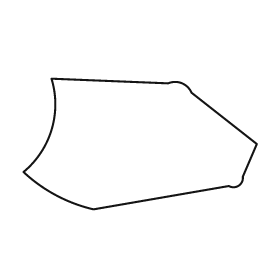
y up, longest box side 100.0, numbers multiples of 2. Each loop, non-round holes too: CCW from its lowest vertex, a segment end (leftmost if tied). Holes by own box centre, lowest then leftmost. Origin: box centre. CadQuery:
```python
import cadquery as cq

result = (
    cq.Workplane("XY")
    .moveTo(-20.0, -28.0)
    .lineTo(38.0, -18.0)
    .threePointArc((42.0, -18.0), (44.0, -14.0))
    .lineTo(50.0, 0.0)
    .lineTo(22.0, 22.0)
    .threePointArc((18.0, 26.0), (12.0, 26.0))
    .lineTo(-38.0, 28.0)
    .threePointArc((-38.0, 6.0), (-50.0, -12.0))
    .threePointArc((-36.0, -22.0), (-20.0, -28.0))
    .close()
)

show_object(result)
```